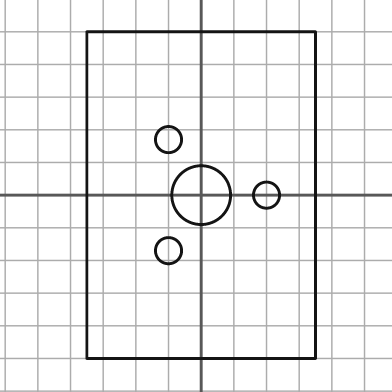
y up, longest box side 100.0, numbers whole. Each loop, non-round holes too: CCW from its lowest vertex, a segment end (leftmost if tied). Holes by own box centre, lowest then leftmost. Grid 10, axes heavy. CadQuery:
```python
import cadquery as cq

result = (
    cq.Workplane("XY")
    .moveTo(-35.0, -50.0)
    .lineTo(35.0, -50.0)
    .lineTo(35.0, 50.0)
    .lineTo(-35.0, 50.0)
    .close()
    .moveTo(-10.0, -17.0)
    .circle(4.0)
    .moveTo(0.0, 0.0)
    .circle(9.0)
    .moveTo(20.0, 0.0)
    .circle(4.0)
    .moveTo(-10.0, 17.0)
    .circle(4.0)
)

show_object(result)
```